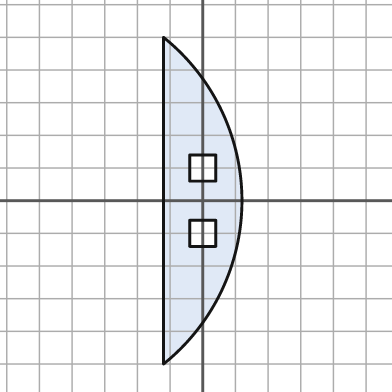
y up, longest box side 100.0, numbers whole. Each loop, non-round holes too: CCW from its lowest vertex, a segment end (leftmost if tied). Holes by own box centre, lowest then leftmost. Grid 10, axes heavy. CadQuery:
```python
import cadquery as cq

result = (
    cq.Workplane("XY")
    .moveTo(-12.0, -50.0)
    .threePointArc((12.0, 0.0), (-12.0, 50.0))
    .close()
    .moveTo(-4.0, -14.0)
    .lineTo(4.0, -14.0)
    .lineTo(4.0, -6.0)
    .lineTo(-4.0, -6.0)
    .close()
    .moveTo(-4.0, 6.0)
    .lineTo(4.0, 6.0)
    .lineTo(4.0, 14.0)
    .lineTo(-4.0, 14.0)
    .close()
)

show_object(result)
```